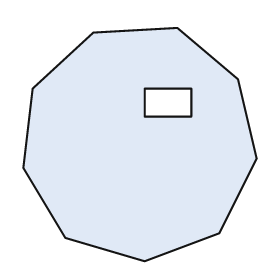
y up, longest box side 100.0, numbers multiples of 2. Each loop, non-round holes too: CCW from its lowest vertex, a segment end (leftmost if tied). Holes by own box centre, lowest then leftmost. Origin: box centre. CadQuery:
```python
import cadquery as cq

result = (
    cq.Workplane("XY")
    .moveTo(2.0, -50.0)
    .lineTo(34.0, -38.0)
    .lineTo(50.0, -6.0)
    .lineTo(42.0, 28.0)
    .lineTo(16.0, 50.0)
    .lineTo(-20.0, 48.0)
    .lineTo(-46.0, 24.0)
    .lineTo(-50.0, -10.0)
    .lineTo(-32.0, -40.0)
    .close()
    .moveTo(2.0, 12.0)
    .lineTo(22.0, 12.0)
    .lineTo(22.0, 24.0)
    .lineTo(2.0, 24.0)
    .close()
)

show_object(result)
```